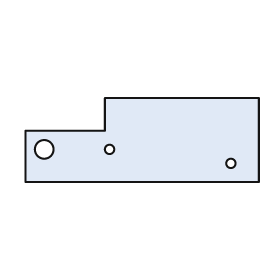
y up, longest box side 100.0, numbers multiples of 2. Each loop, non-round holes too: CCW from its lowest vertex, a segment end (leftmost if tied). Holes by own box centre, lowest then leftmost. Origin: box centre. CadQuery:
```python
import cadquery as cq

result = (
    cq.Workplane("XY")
    .moveTo(-50.0, -18.0)
    .lineTo(50.0, -18.0)
    .lineTo(50.0, 18.0)
    .lineTo(-16.0, 18.0)
    .lineTo(-16.0, 4.0)
    .lineTo(-50.0, 4.0)
    .close()
    .moveTo(38.0, -10.0)
    .circle(2.0)
    .moveTo(-42.0, -4.0)
    .circle(4.0)
    .moveTo(-14.0, -4.0)
    .circle(2.0)
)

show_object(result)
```